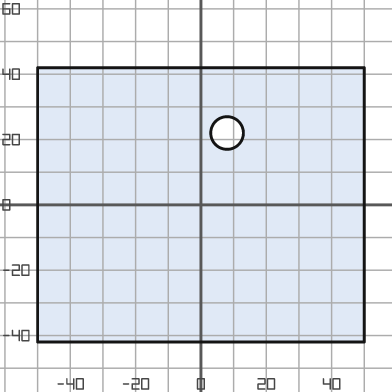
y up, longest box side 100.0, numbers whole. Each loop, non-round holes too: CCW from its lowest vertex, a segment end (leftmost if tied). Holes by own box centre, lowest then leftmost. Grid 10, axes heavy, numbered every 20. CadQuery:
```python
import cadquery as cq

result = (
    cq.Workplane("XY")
    .moveTo(-50.0, -42.0)
    .lineTo(50.0, -42.0)
    .lineTo(50.0, 42.0)
    .lineTo(-50.0, 42.0)
    .close()
    .moveTo(8.0, 22.0)
    .circle(5.0)
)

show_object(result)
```